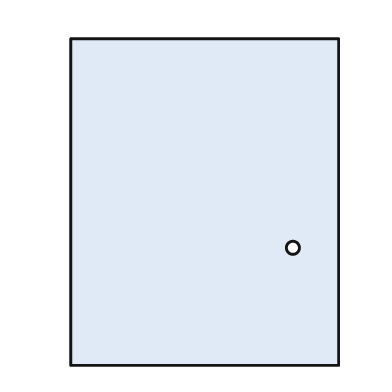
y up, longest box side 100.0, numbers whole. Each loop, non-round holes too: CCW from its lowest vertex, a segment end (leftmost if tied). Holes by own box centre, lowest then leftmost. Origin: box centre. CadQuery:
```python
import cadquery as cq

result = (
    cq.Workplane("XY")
    .moveTo(-41.0, -50.0)
    .lineTo(41.0, -50.0)
    .lineTo(41.0, 50.0)
    .lineTo(-41.0, 50.0)
    .close()
    .moveTo(27.0, -14.0)
    .circle(2.0)
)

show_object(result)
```